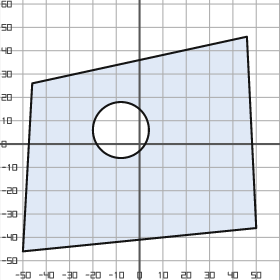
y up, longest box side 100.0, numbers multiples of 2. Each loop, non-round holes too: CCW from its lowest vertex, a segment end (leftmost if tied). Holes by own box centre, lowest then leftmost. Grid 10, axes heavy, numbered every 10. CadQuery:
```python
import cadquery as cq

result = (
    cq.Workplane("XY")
    .moveTo(-50.0, -46.0)
    .lineTo(50.0, -36.0)
    .lineTo(46.0, 46.0)
    .lineTo(-46.0, 26.0)
    .close()
    .moveTo(-8.0, 6.0)
    .circle(12.0)
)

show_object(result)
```